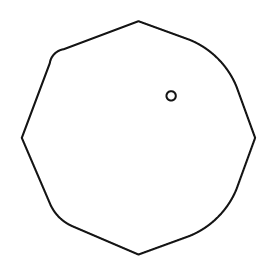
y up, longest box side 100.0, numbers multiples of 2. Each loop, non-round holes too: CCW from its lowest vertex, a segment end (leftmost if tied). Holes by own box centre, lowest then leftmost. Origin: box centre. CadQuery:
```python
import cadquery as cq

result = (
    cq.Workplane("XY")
    .moveTo(0.0, -50.0)
    .lineTo(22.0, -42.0)
    .threePointArc((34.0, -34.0), (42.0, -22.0))
    .lineTo(50.0, 0.0)
    .lineTo(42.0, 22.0)
    .threePointArc((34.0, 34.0), (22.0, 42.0))
    .lineTo(0.0, 50.0)
    .lineTo(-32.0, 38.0)
    .threePointArc((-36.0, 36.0), (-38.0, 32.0))
    .lineTo(-50.0, 0.0)
    .lineTo(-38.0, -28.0)
    .threePointArc((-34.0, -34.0), (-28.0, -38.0))
    .close()
    .moveTo(14.0, 18.0)
    .circle(2.0)
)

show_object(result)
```